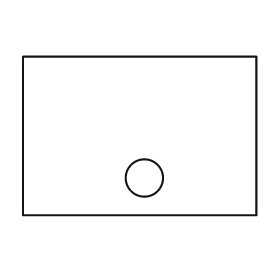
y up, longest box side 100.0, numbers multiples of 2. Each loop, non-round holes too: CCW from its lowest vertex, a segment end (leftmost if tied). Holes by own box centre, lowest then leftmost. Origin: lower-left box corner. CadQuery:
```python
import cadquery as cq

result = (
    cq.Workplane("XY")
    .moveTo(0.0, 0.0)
    .lineTo(100.0, 0.0)
    .lineTo(100.0, 68.0)
    .lineTo(0.0, 68.0)
    .close()
    .moveTo(52.0, 16.0)
    .circle(8.0)
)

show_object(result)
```